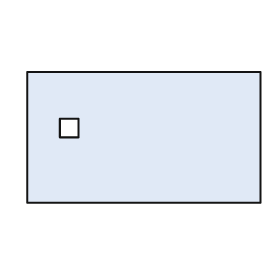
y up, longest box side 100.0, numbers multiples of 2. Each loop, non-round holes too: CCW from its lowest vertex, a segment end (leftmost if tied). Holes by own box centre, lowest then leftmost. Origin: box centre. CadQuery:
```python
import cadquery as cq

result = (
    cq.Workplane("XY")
    .moveTo(-50.0, -28.0)
    .lineTo(50.0, -28.0)
    .lineTo(50.0, 28.0)
    .lineTo(-50.0, 28.0)
    .close()
    .moveTo(-36.0, 0.0)
    .lineTo(-28.0, 0.0)
    .lineTo(-28.0, 8.0)
    .lineTo(-36.0, 8.0)
    .close()
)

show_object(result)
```